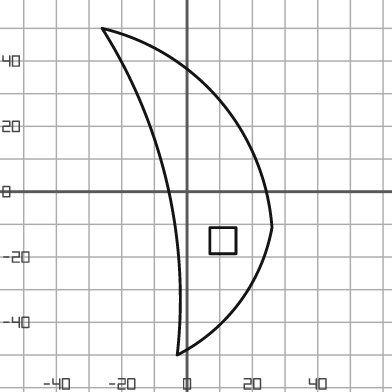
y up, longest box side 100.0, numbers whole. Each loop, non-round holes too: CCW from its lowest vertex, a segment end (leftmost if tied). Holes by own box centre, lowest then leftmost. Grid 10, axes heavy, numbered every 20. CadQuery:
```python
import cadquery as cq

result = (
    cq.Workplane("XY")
    .moveTo(-3.0, -50.0)
    .threePointArc((16.0, -34.0), (26.0, -11.0))
    .threePointArc((10.0, 28.0), (-26.0, 50.0))
    .threePointArc((-6.0, 2.0), (-3.0, -50.0))
    .close()
    .moveTo(7.0, -19.0)
    .lineTo(15.0, -19.0)
    .lineTo(15.0, -11.0)
    .lineTo(7.0, -11.0)
    .close()
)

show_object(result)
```